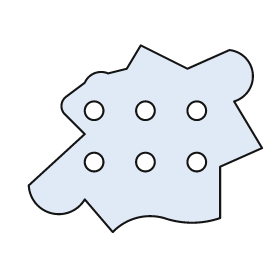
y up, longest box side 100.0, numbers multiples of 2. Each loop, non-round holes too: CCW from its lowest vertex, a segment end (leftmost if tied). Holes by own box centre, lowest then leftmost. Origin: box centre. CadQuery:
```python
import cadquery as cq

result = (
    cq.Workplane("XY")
    .moveTo(-14.0, -40.0)
    .threePointArc((-4.0, -34.0), (8.0, -34.0))
    .threePointArc((20.0, -36.0), (32.0, -34.0))
    .lineTo(32.0, -12.0)
    .lineTo(50.0, -4.0)
    .lineTo(38.0, 16.0)
    .threePointArc((46.0, 28.0), (36.0, 38.0))
    .lineTo(18.0, 30.0)
    .lineTo(-2.0, 40.0)
    .lineTo(-8.0, 30.0)
    .lineTo(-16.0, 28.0)
    .threePointArc((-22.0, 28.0), (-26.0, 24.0))
    .lineTo(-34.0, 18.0)
    .threePointArc((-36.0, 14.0), (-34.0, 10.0))
    .lineTo(-26.0, 2.0)
    .lineTo(-50.0, -20.0)
    .threePointArc((-40.0, -32.0), (-26.0, -26.0))
    .close()
    .moveTo(-22.0, -10.0)
    .circle(4.0)
    .moveTo(0.0, -10.0)
    .circle(4.0)
    .moveTo(22.0, -10.0)
    .circle(4.0)
    .moveTo(-22.0, 12.0)
    .circle(4.0)
    .moveTo(0.0, 12.0)
    .circle(4.0)
    .moveTo(22.0, 12.0)
    .circle(4.0)
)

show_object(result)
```